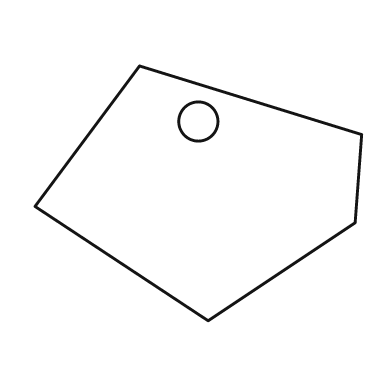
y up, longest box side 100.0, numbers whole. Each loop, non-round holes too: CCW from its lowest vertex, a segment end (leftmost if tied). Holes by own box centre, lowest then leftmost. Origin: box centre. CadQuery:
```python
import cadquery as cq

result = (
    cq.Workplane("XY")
    .moveTo(3.0, -39.0)
    .lineTo(48.0, -9.0)
    .lineTo(50.0, 18.0)
    .lineTo(-18.0, 39.0)
    .lineTo(-50.0, -4.0)
    .close()
    .moveTo(0.0, 22.0)
    .circle(6.0)
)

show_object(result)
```